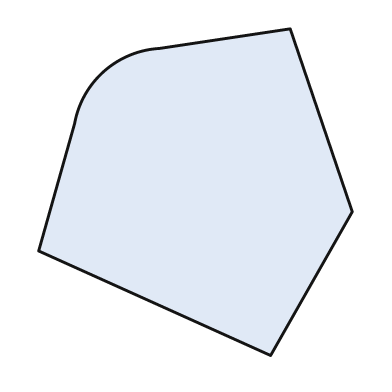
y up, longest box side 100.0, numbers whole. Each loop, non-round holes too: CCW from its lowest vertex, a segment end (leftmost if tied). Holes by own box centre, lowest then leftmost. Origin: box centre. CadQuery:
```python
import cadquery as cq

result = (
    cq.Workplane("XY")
    .moveTo(23.0, -50.0)
    .lineTo(48.0, -6.0)
    .lineTo(29.0, 50.0)
    .lineTo(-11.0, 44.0)
    .threePointArc((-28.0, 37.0), (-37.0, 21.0))
    .lineTo(-48.0, -18.0)
    .close()
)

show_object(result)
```